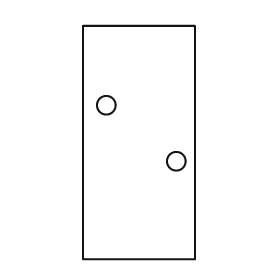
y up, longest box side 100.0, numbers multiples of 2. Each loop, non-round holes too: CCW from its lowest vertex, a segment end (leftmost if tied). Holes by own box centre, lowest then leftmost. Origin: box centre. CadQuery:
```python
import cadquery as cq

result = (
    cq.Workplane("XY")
    .moveTo(-24.0, -50.0)
    .lineTo(24.0, -50.0)
    .lineTo(24.0, 50.0)
    .lineTo(-24.0, 50.0)
    .close()
    .moveTo(16.0, -8.0)
    .circle(4.0)
    .moveTo(-14.0, 16.0)
    .circle(4.0)
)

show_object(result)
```